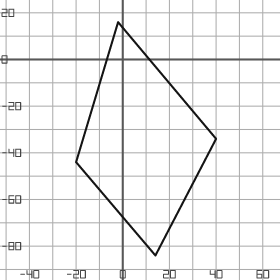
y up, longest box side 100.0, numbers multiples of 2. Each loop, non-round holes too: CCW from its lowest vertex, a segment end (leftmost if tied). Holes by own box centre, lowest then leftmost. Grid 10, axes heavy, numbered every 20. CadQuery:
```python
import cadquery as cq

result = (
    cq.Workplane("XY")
    .moveTo(14.0, -84.0)
    .lineTo(40.0, -34.0)
    .lineTo(-2.0, 16.0)
    .lineTo(-20.0, -44.0)
    .close()
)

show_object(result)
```